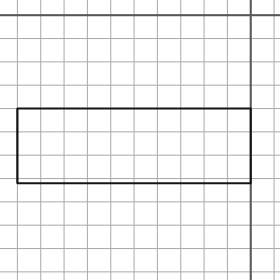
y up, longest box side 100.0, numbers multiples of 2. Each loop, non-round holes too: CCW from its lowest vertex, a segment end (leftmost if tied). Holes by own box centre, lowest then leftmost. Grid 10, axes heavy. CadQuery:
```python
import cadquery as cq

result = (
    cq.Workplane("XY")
    .moveTo(-100.0, -72.0)
    .lineTo(0.0, -72.0)
    .lineTo(0.0, -40.0)
    .lineTo(-100.0, -40.0)
    .close()
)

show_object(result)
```